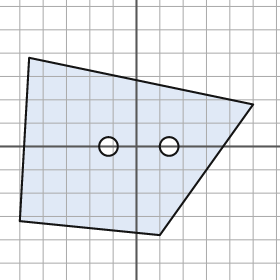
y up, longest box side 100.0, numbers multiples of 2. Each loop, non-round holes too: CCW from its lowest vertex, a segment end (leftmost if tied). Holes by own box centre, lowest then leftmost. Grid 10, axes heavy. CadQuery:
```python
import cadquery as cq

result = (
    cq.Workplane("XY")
    .moveTo(10.0, -38.0)
    .lineTo(50.0, 18.0)
    .lineTo(-46.0, 38.0)
    .lineTo(-50.0, -32.0)
    .close()
    .moveTo(-12.0, 0.0)
    .circle(4.0)
    .moveTo(14.0, 0.0)
    .circle(4.0)
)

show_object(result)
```